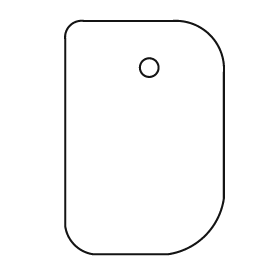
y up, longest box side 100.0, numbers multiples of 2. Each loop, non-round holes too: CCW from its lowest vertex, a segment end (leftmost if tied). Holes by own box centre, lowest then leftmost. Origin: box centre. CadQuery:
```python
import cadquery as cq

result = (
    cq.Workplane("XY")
    .moveTo(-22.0, -50.0)
    .lineTo(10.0, -50.0)
    .threePointArc((26.0, -42.0), (34.0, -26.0))
    .lineTo(34.0, 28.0)
    .threePointArc((28.0, 44.0), (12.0, 50.0))
    .lineTo(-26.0, 50.0)
    .threePointArc((-32.0, 48.0), (-34.0, 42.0))
    .lineTo(-34.0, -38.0)
    .threePointArc((-30.0, -46.0), (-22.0, -50.0))
    .close()
    .moveTo(2.0, 30.0)
    .circle(4.0)
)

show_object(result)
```